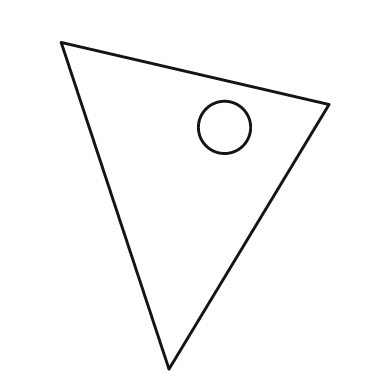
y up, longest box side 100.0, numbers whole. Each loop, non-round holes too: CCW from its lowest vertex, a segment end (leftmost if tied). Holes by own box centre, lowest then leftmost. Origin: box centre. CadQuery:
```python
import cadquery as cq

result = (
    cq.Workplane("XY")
    .moveTo(-8.0, -50.0)
    .lineTo(41.0, 31.0)
    .lineTo(-41.0, 50.0)
    .close()
    .moveTo(9.0, 24.0)
    .circle(8.0)
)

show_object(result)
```